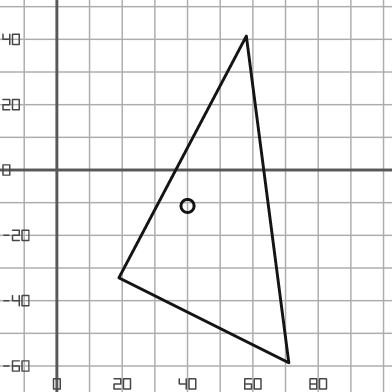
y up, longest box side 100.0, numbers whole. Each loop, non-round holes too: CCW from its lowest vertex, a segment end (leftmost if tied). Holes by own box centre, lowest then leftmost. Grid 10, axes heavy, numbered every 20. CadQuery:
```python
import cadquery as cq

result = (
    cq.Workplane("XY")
    .moveTo(71.0, -59.0)
    .lineTo(58.0, 41.0)
    .lineTo(19.0, -33.0)
    .close()
    .moveTo(40.0, -11.0)
    .circle(2.0)
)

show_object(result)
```